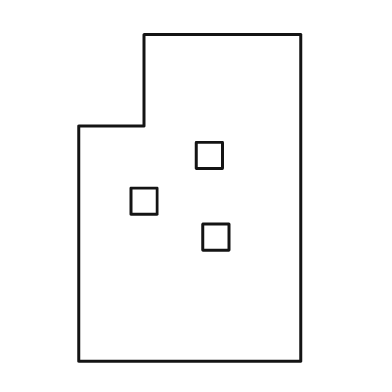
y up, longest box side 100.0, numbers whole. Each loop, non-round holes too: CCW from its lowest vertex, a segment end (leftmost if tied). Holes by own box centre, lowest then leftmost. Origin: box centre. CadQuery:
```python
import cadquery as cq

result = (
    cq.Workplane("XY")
    .moveTo(-34.0, -50.0)
    .lineTo(34.0, -50.0)
    .lineTo(34.0, 50.0)
    .lineTo(-14.0, 50.0)
    .lineTo(-14.0, 22.0)
    .lineTo(-34.0, 22.0)
    .close()
    .moveTo(4.0, -16.0)
    .lineTo(12.0, -16.0)
    .lineTo(12.0, -8.0)
    .lineTo(4.0, -8.0)
    .close()
    .moveTo(-18.0, -5.0)
    .lineTo(-10.0, -5.0)
    .lineTo(-10.0, 3.0)
    .lineTo(-18.0, 3.0)
    .close()
    .moveTo(2.0, 9.0)
    .lineTo(10.0, 9.0)
    .lineTo(10.0, 17.0)
    .lineTo(2.0, 17.0)
    .close()
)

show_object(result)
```